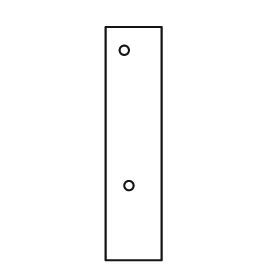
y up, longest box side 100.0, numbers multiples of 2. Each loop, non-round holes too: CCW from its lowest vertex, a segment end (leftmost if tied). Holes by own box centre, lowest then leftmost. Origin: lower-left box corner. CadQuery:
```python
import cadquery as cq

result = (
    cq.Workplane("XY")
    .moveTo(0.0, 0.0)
    .lineTo(24.0, 0.0)
    .lineTo(24.0, 100.0)
    .lineTo(0.0, 100.0)
    .close()
    .moveTo(10.0, 32.0)
    .circle(2.0)
    .moveTo(8.0, 90.0)
    .circle(2.0)
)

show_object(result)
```